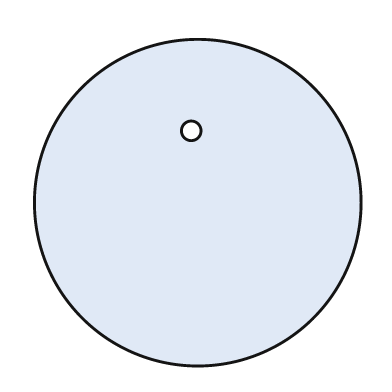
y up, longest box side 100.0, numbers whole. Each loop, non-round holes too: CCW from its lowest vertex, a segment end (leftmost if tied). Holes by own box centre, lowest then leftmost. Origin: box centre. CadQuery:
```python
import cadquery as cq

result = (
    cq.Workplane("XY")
    .moveTo(0.0, 0.0)
    .circle(50.0)
    .moveTo(-2.0, 22.0)
    .circle(3.0)
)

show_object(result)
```